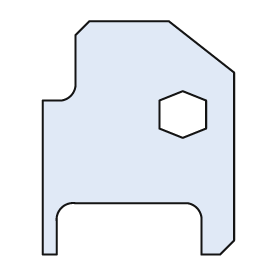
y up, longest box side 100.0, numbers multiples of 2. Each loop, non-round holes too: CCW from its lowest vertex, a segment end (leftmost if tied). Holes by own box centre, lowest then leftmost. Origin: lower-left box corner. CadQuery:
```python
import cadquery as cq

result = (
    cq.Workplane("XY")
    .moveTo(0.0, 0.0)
    .lineTo(6.0, 0.0)
    .lineTo(6.0, 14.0)
    .threePointArc((8.0, 20.0), (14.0, 22.0))
    .lineTo(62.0, 22.0)
    .threePointArc((66.0, 20.0), (68.0, 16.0))
    .lineTo(68.0, 0.0)
    .lineTo(76.0, 0.0)
    .lineTo(82.0, 6.0)
    .lineTo(82.0, 78.0)
    .lineTo(54.0, 100.0)
    .lineTo(20.0, 100.0)
    .lineTo(14.0, 94.0)
    .lineTo(14.0, 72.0)
    .threePointArc((12.0, 68.0), (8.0, 66.0))
    .lineTo(0.0, 66.0)
    .close()
    .moveTo(60.0, 50.0)
    .lineTo(70.0, 54.0)
    .lineTo(70.0, 66.0)
    .lineTo(60.0, 70.0)
    .lineTo(50.0, 66.0)
    .lineTo(50.0, 54.0)
    .close()
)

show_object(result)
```